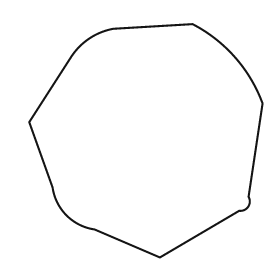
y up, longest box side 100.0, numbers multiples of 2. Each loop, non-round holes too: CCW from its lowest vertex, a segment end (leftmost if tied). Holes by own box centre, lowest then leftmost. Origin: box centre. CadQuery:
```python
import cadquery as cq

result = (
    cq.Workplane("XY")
    .moveTo(6.0, -50.0)
    .lineTo(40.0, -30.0)
    .threePointArc((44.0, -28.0), (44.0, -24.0))
    .lineTo(50.0, 16.0)
    .threePointArc((38.0, 36.0), (20.0, 50.0))
    .lineTo(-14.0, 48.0)
    .threePointArc((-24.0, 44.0), (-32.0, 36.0))
    .lineTo(-50.0, 8.0)
    .lineTo(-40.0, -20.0)
    .threePointArc((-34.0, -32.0), (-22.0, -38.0))
    .close()
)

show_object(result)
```